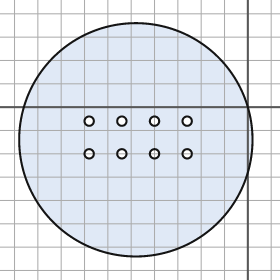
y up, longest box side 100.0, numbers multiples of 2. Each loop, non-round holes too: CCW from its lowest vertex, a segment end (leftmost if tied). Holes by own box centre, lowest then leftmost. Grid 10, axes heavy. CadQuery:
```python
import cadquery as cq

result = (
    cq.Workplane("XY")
    .moveTo(-48.0, -14.0)
    .circle(50.0)
    .moveTo(-68.0, -20.0)
    .circle(2.0)
    .moveTo(-54.0, -20.0)
    .circle(2.0)
    .moveTo(-40.0, -20.0)
    .circle(2.0)
    .moveTo(-26.0, -20.0)
    .circle(2.0)
    .moveTo(-68.0, -6.0)
    .circle(2.0)
    .moveTo(-54.0, -6.0)
    .circle(2.0)
    .moveTo(-40.0, -6.0)
    .circle(2.0)
    .moveTo(-26.0, -6.0)
    .circle(2.0)
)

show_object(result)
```